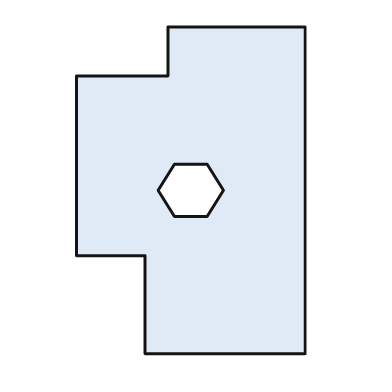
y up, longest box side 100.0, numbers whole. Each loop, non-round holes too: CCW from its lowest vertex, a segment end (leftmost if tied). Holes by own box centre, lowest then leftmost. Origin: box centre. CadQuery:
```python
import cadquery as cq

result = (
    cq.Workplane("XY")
    .moveTo(-14.0, -50.0)
    .lineTo(35.0, -50.0)
    .lineTo(35.0, 50.0)
    .lineTo(-7.0, 50.0)
    .lineTo(-7.0, 35.0)
    .lineTo(-35.0, 35.0)
    .lineTo(-35.0, -20.0)
    .lineTo(-14.0, -20.0)
    .close()
    .moveTo(-5.0, -8.0)
    .lineTo(5.0, -8.0)
    .lineTo(10.0, 0.0)
    .lineTo(5.0, 8.0)
    .lineTo(-5.0, 8.0)
    .lineTo(-10.0, 0.0)
    .close()
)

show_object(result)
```